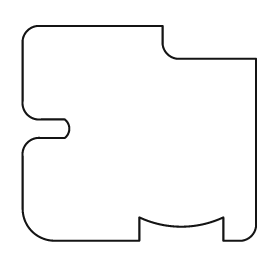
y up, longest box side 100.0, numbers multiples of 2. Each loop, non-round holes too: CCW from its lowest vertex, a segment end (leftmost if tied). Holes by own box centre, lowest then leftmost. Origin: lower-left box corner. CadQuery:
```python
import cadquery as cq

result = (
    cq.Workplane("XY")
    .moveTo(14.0, 0.0)
    .lineTo(50.0, 0.0)
    .lineTo(50.0, 10.0)
    .threePointArc((68.0, 6.0), (86.0, 10.0))
    .lineTo(86.0, 0.0)
    .lineTo(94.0, 0.0)
    .threePointArc((98.0, 2.0), (100.0, 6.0))
    .lineTo(100.0, 78.0)
    .lineTo(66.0, 78.0)
    .threePointArc((62.0, 80.0), (60.0, 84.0))
    .lineTo(60.0, 92.0)
    .lineTo(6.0, 92.0)
    .threePointArc((2.0, 90.0), (0.0, 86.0))
    .lineTo(0.0, 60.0)
    .threePointArc((2.0, 54.0), (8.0, 52.0))
    .lineTo(18.0, 52.0)
    .threePointArc((20.0, 48.0), (18.0, 44.0))
    .lineTo(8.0, 44.0)
    .threePointArc((2.0, 42.0), (0.0, 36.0))
    .lineTo(0.0, 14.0)
    .threePointArc((4.0, 4.0), (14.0, 0.0))
    .close()
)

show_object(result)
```